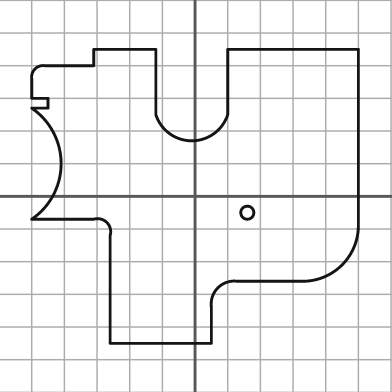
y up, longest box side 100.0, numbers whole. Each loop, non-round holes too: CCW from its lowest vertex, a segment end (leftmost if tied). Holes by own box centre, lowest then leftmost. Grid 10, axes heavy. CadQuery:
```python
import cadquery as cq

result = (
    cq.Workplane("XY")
    .moveTo(-26.0, -45.0)
    .lineTo(5.0, -45.0)
    .lineTo(5.0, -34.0)
    .threePointArc((7.0, -28.0), (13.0, -26.0))
    .lineTo(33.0, -26.0)
    .threePointArc((45.0, -21.0), (50.0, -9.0))
    .lineTo(50.0, 45.0)
    .lineTo(10.0, 45.0)
    .lineTo(10.0, 25.0)
    .threePointArc((-1.0, 17.0), (-12.0, 25.0))
    .lineTo(-12.0, 45.0)
    .lineTo(-31.0, 45.0)
    .lineTo(-31.0, 40.0)
    .lineTo(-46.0, 40.0)
    .threePointArc((-49.0, 39.0), (-50.0, 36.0))
    .lineTo(-50.0, 30.0)
    .lineTo(-45.0, 30.0)
    .lineTo(-45.0, 27.0)
    .lineTo(-50.0, 27.0)
    .threePointArc((-41.0, 10.0), (-50.0, -7.0))
    .lineTo(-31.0, -7.0)
    .threePointArc((-27.0, -8.0), (-26.0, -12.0))
    .close()
    .moveTo(16.0, -5.0)
    .circle(2.0)
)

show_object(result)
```